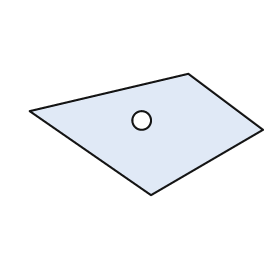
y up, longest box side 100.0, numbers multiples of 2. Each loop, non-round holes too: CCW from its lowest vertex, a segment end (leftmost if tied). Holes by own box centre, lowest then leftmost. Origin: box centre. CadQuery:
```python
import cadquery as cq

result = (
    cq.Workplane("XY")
    .moveTo(2.0, -26.0)
    .lineTo(50.0, 2.0)
    .lineTo(18.0, 26.0)
    .lineTo(-50.0, 10.0)
    .close()
    .moveTo(-2.0, 6.0)
    .circle(4.0)
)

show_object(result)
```